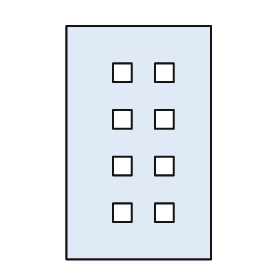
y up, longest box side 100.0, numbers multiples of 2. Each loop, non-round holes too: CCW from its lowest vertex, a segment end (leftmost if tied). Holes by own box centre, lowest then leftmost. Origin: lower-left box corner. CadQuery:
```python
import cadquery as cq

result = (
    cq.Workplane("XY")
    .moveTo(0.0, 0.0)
    .lineTo(62.0, 0.0)
    .lineTo(62.0, 100.0)
    .lineTo(0.0, 100.0)
    .close()
    .moveTo(20.0, 16.0)
    .lineTo(28.0, 16.0)
    .lineTo(28.0, 24.0)
    .lineTo(20.0, 24.0)
    .close()
    .moveTo(38.0, 16.0)
    .lineTo(46.0, 16.0)
    .lineTo(46.0, 24.0)
    .lineTo(38.0, 24.0)
    .close()
    .moveTo(20.0, 36.0)
    .lineTo(28.0, 36.0)
    .lineTo(28.0, 44.0)
    .lineTo(20.0, 44.0)
    .close()
    .moveTo(38.0, 36.0)
    .lineTo(46.0, 36.0)
    .lineTo(46.0, 44.0)
    .lineTo(38.0, 44.0)
    .close()
    .moveTo(20.0, 56.0)
    .lineTo(28.0, 56.0)
    .lineTo(28.0, 64.0)
    .lineTo(20.0, 64.0)
    .close()
    .moveTo(38.0, 56.0)
    .lineTo(46.0, 56.0)
    .lineTo(46.0, 64.0)
    .lineTo(38.0, 64.0)
    .close()
    .moveTo(20.0, 76.0)
    .lineTo(28.0, 76.0)
    .lineTo(28.0, 84.0)
    .lineTo(20.0, 84.0)
    .close()
    .moveTo(38.0, 76.0)
    .lineTo(46.0, 76.0)
    .lineTo(46.0, 84.0)
    .lineTo(38.0, 84.0)
    .close()
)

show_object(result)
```